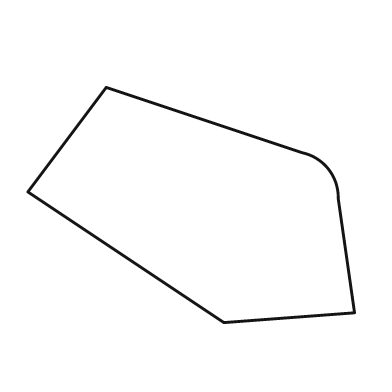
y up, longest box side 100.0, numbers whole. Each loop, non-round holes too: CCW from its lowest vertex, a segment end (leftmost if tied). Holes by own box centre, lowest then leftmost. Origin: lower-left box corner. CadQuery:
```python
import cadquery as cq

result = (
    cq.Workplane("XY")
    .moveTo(60.0, 0.0)
    .lineTo(100.0, 3.0)
    .lineTo(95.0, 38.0)
    .threePointArc((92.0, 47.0), (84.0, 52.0))
    .lineTo(24.0, 72.0)
    .lineTo(0.0, 40.0)
    .close()
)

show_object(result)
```